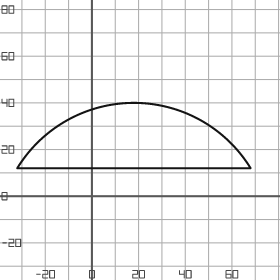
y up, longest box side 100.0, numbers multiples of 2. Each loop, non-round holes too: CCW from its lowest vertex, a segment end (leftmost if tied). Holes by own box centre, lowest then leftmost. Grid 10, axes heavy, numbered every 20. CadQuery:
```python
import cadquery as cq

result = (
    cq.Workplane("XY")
    .moveTo(-32.0, 12.0)
    .lineTo(68.0, 12.0)
    .threePointArc((18.0, 40.0), (-32.0, 12.0))
    .close()
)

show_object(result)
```